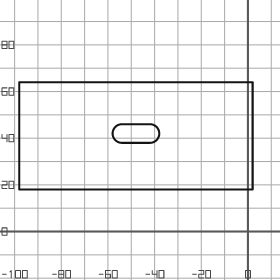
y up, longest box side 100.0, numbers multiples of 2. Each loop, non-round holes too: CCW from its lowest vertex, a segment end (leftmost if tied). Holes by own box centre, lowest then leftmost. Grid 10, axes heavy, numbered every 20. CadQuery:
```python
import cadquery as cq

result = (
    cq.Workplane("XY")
    .moveTo(-98.0, 18.0)
    .lineTo(2.0, 18.0)
    .lineTo(2.0, 64.0)
    .lineTo(-98.0, 64.0)
    .close()
    .moveTo(-54.0, 38.0)
    .lineTo(-42.0, 38.0)
    .threePointArc((-38.0, 42.0), (-42.0, 46.0))
    .lineTo(-54.0, 46.0)
    .threePointArc((-58.0, 42.0), (-54.0, 38.0))
    .close()
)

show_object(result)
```